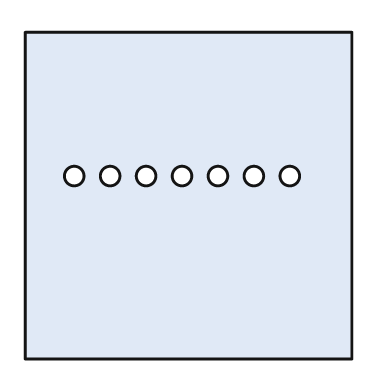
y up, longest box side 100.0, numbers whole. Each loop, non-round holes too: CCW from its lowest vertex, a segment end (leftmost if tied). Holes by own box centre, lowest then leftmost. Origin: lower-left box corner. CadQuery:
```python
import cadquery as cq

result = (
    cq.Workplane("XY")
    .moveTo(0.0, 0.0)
    .lineTo(100.0, 0.0)
    .lineTo(100.0, 100.0)
    .lineTo(0.0, 100.0)
    .close()
    .moveTo(15.0, 56.0)
    .circle(3.0)
    .moveTo(26.0, 56.0)
    .circle(3.0)
    .moveTo(37.0, 56.0)
    .circle(3.0)
    .moveTo(48.0, 56.0)
    .circle(3.0)
    .moveTo(59.0, 56.0)
    .circle(3.0)
    .moveTo(70.0, 56.0)
    .circle(3.0)
    .moveTo(81.0, 56.0)
    .circle(3.0)
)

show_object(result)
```